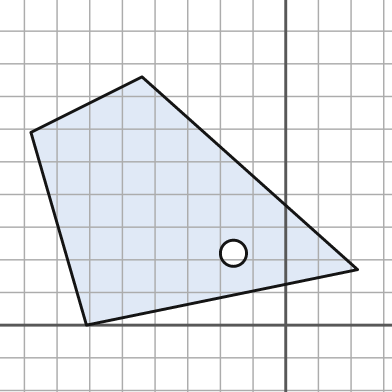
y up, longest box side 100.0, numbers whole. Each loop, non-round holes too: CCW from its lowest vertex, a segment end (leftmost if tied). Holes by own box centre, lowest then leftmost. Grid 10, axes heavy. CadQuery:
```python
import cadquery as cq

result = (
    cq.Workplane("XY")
    .moveTo(-61.0, 0.0)
    .lineTo(22.0, 17.0)
    .lineTo(-44.0, 76.0)
    .lineTo(-78.0, 59.0)
    .close()
    .moveTo(-16.0, 22.0)
    .circle(4.0)
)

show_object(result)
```